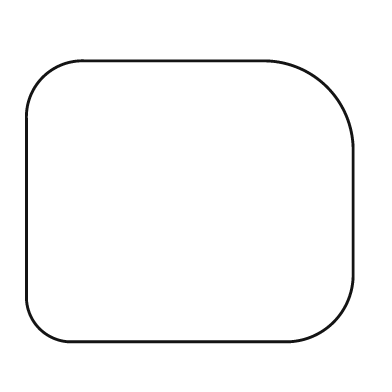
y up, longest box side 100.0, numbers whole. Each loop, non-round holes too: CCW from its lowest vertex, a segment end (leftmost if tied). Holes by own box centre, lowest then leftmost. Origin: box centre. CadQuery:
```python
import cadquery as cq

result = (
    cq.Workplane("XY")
    .moveTo(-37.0, -43.0)
    .lineTo(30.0, -43.0)
    .threePointArc((44.0, -37.0), (50.0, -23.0))
    .lineTo(50.0, 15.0)
    .threePointArc((42.0, 35.0), (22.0, 43.0))
    .lineTo(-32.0, 43.0)
    .threePointArc((-45.0, 38.0), (-50.0, 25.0))
    .lineTo(-50.0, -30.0)
    .threePointArc((-46.0, -39.0), (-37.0, -43.0))
    .close()
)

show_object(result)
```